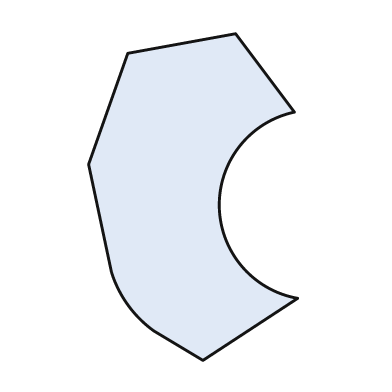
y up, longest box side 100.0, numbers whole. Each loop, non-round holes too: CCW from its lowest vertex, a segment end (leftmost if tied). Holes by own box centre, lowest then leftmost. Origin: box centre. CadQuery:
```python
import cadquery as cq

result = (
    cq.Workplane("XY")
    .moveTo(3.0, -50.0)
    .lineTo(32.0, -31.0)
    .threePointArc((8.0, -3.0), (31.0, 26.0))
    .lineTo(13.0, 50.0)
    .lineTo(-20.0, 44.0)
    .lineTo(-32.0, 10.0)
    .lineTo(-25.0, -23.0)
    .threePointArc((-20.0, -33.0), (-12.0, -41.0))
    .close()
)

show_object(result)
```